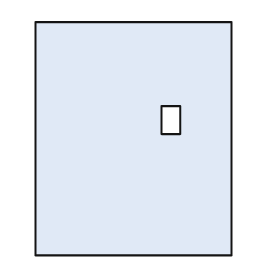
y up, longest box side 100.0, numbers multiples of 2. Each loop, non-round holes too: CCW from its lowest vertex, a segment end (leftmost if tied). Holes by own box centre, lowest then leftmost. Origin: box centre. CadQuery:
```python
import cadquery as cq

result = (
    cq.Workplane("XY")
    .moveTo(-42.0, -50.0)
    .lineTo(42.0, -50.0)
    .lineTo(42.0, 50.0)
    .lineTo(-42.0, 50.0)
    .close()
    .moveTo(12.0, 2.0)
    .lineTo(20.0, 2.0)
    .lineTo(20.0, 14.0)
    .lineTo(12.0, 14.0)
    .close()
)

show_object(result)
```